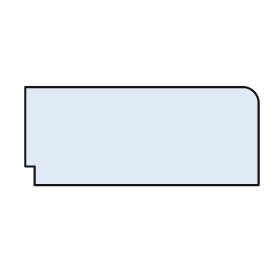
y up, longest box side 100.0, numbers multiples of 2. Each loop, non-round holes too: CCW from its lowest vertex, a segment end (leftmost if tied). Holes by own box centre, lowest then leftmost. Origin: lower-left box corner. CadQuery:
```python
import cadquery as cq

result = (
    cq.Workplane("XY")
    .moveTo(4.0, 0.0)
    .lineTo(100.0, 0.0)
    .lineTo(100.0, 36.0)
    .threePointArc((98.0, 40.0), (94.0, 42.0))
    .lineTo(0.0, 42.0)
    .lineTo(0.0, 8.0)
    .lineTo(4.0, 8.0)
    .close()
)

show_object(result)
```